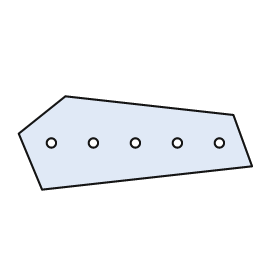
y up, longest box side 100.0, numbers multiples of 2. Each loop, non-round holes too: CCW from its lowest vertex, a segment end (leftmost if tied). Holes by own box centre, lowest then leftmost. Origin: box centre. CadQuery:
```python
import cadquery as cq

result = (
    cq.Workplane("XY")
    .moveTo(-40.0, -20.0)
    .lineTo(50.0, -10.0)
    .lineTo(42.0, 12.0)
    .lineTo(-30.0, 20.0)
    .lineTo(-50.0, 4.0)
    .close()
    .moveTo(-36.0, 0.0)
    .circle(2.0)
    .moveTo(-18.0, 0.0)
    .circle(2.0)
    .moveTo(0.0, 0.0)
    .circle(2.0)
    .moveTo(18.0, 0.0)
    .circle(2.0)
    .moveTo(36.0, 0.0)
    .circle(2.0)
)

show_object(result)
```